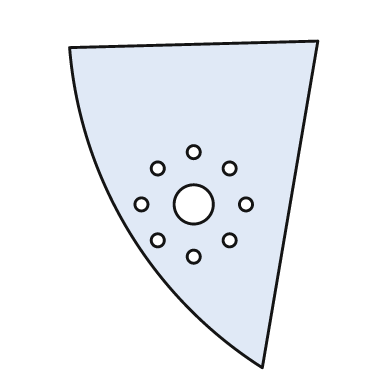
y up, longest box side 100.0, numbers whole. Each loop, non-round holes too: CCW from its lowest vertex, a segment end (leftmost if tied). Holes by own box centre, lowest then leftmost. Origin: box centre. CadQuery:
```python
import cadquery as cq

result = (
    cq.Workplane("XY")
    .moveTo(21.0, -50.0)
    .lineTo(38.0, 50.0)
    .lineTo(-38.0, 48.0)
    .threePointArc((-20.0, -8.0), (21.0, -50.0))
    .close()
    .moveTo(0.0, -16.0)
    .circle(2.0)
    .moveTo(-11.0, -11.0)
    .circle(2.0)
    .moveTo(11.0, -11.0)
    .circle(2.0)
    .moveTo(-16.0, 0.0)
    .circle(2.0)
    .moveTo(0.0, 0.0)
    .circle(6.0)
    .moveTo(16.0, 0.0)
    .circle(2.0)
    .moveTo(-11.0, 11.0)
    .circle(2.0)
    .moveTo(11.0, 11.0)
    .circle(2.0)
    .moveTo(0.0, 16.0)
    .circle(2.0)
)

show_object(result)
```